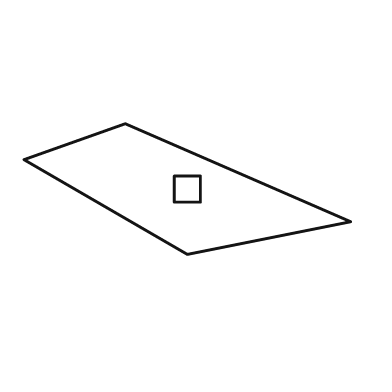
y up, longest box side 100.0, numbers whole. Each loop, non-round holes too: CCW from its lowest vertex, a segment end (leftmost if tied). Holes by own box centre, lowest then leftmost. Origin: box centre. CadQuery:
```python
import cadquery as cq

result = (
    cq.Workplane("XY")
    .moveTo(0.0, -20.0)
    .lineTo(50.0, -10.0)
    .lineTo(-19.0, 20.0)
    .lineTo(-50.0, 9.0)
    .close()
    .moveTo(-4.0, -4.0)
    .lineTo(4.0, -4.0)
    .lineTo(4.0, 4.0)
    .lineTo(-4.0, 4.0)
    .close()
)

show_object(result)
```